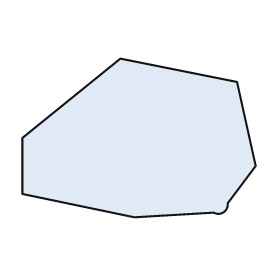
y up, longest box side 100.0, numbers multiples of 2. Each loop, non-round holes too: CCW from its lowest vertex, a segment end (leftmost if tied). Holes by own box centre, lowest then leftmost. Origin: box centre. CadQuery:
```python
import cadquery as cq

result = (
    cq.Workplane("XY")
    .moveTo(-2.0, -34.0)
    .lineTo(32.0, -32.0)
    .threePointArc((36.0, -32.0), (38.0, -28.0))
    .lineTo(50.0, -12.0)
    .lineTo(42.0, 24.0)
    .lineTo(-8.0, 34.0)
    .lineTo(-50.0, 0.0)
    .lineTo(-50.0, -24.0)
    .close()
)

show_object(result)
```